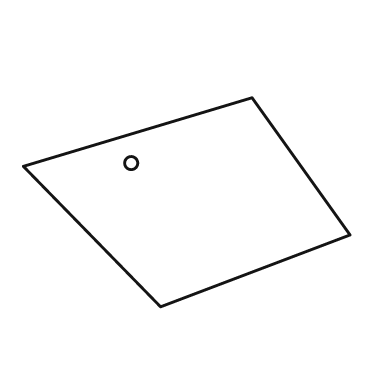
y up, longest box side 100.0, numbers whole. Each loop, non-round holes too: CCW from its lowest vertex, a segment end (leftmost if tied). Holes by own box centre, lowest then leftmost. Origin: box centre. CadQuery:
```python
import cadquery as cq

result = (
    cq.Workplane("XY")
    .moveTo(-8.0, -32.0)
    .lineTo(50.0, -10.0)
    .lineTo(20.0, 32.0)
    .lineTo(-50.0, 11.0)
    .close()
    .moveTo(-17.0, 12.0)
    .circle(2.0)
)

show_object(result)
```